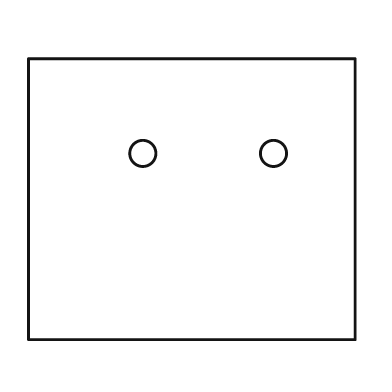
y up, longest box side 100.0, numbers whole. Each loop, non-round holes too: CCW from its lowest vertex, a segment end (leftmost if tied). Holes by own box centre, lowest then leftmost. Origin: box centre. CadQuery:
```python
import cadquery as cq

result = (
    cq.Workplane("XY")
    .moveTo(-50.0, -43.0)
    .lineTo(50.0, -43.0)
    .lineTo(50.0, 43.0)
    .lineTo(-50.0, 43.0)
    .close()
    .moveTo(-15.0, 14.0)
    .circle(4.0)
    .moveTo(25.0, 14.0)
    .circle(4.0)
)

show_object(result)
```